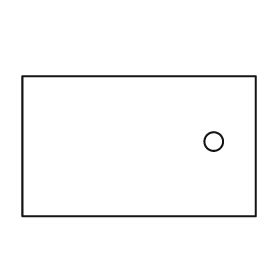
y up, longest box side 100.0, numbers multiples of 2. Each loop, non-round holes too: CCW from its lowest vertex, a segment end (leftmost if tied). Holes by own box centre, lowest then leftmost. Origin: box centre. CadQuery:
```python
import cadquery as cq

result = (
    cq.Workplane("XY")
    .moveTo(-50.0, -30.0)
    .lineTo(50.0, -30.0)
    .lineTo(50.0, 30.0)
    .lineTo(-50.0, 30.0)
    .close()
    .moveTo(32.0, 2.0)
    .circle(4.0)
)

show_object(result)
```